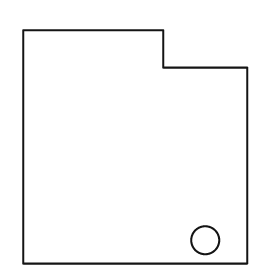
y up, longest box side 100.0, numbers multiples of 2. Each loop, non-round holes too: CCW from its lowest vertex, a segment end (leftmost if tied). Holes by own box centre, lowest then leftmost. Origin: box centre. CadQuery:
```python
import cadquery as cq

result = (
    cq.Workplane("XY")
    .moveTo(-48.0, -50.0)
    .lineTo(48.0, -50.0)
    .lineTo(48.0, 34.0)
    .lineTo(12.0, 34.0)
    .lineTo(12.0, 50.0)
    .lineTo(-48.0, 50.0)
    .close()
    .moveTo(30.0, -40.0)
    .circle(6.0)
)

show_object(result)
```